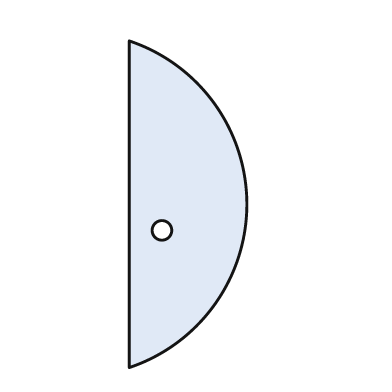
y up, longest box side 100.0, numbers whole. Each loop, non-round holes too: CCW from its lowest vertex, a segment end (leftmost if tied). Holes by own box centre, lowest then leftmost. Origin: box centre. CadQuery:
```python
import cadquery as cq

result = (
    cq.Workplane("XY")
    .moveTo(-18.0, -50.0)
    .threePointArc((18.0, 0.0), (-18.0, 50.0))
    .close()
    .moveTo(-8.0, -8.0)
    .circle(3.0)
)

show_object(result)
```